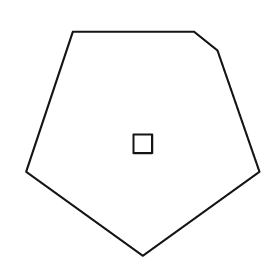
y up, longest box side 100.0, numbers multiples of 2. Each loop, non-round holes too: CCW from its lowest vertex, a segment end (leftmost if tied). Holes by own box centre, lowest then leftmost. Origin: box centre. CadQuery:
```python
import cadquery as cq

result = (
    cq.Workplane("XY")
    .moveTo(0.0, -48.0)
    .lineTo(50.0, -12.0)
    .lineTo(32.0, 40.0)
    .lineTo(22.0, 48.0)
    .lineTo(-30.0, 48.0)
    .lineTo(-50.0, -12.0)
    .close()
    .moveTo(-4.0, -4.0)
    .lineTo(4.0, -4.0)
    .lineTo(4.0, 4.0)
    .lineTo(-4.0, 4.0)
    .close()
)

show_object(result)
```